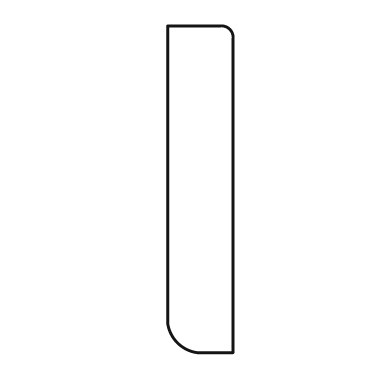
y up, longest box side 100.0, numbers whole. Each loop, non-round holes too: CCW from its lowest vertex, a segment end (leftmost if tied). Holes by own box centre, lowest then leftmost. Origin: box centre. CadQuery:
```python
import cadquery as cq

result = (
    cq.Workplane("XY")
    .moveTo(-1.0, -50.0)
    .lineTo(10.0, -50.0)
    .lineTo(10.0, 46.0)
    .threePointArc((9.0, 49.0), (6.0, 50.0))
    .lineTo(-10.0, 50.0)
    .lineTo(-10.0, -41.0)
    .threePointArc((-7.0, -47.0), (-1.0, -50.0))
    .close()
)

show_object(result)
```